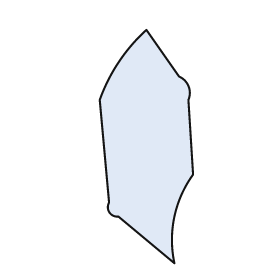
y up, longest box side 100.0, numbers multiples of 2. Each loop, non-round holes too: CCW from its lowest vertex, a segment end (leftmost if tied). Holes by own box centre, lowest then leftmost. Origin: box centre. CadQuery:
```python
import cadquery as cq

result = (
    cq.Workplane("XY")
    .moveTo(12.0, -50.0)
    .threePointArc((12.0, -30.0), (20.0, -12.0))
    .lineTo(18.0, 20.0)
    .threePointArc((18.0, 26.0), (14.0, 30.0))
    .lineTo(0.0, 50.0)
    .threePointArc((-12.0, 36.0), (-20.0, 20.0))
    .lineTo(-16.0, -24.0)
    .threePointArc((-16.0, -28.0), (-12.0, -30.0))
    .close()
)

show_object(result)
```